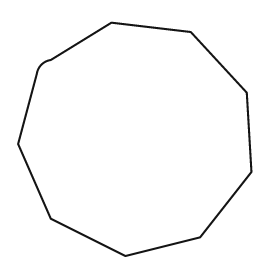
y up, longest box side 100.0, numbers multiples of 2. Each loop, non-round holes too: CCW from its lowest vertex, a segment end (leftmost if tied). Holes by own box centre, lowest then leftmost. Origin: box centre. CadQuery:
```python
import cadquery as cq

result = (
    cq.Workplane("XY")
    .moveTo(-4.0, -50.0)
    .lineTo(28.0, -42.0)
    .lineTo(50.0, -14.0)
    .lineTo(48.0, 20.0)
    .lineTo(24.0, 46.0)
    .lineTo(-10.0, 50.0)
    .lineTo(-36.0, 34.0)
    .threePointArc((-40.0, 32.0), (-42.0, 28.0))
    .lineTo(-50.0, -2.0)
    .lineTo(-36.0, -34.0)
    .close()
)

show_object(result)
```